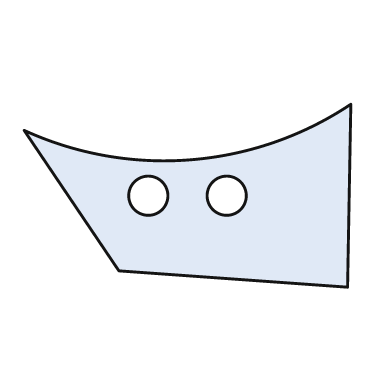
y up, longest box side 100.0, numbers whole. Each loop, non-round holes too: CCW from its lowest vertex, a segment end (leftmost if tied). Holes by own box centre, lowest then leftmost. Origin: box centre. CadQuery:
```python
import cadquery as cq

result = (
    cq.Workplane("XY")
    .moveTo(49.0, -28.0)
    .lineTo(50.0, 28.0)
    .threePointArc((1.0, 11.0), (-50.0, 20.0))
    .lineTo(-21.0, -23.0)
    .close()
    .moveTo(-12.0, 0.0)
    .circle(6.0)
    .moveTo(12.0, 0.0)
    .circle(6.0)
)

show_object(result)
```